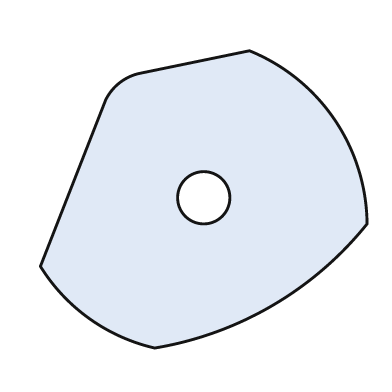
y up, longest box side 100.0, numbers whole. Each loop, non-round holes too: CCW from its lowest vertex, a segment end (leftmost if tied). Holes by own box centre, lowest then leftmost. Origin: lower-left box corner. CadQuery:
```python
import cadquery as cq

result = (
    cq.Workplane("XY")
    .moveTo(35.0, 0.0)
    .threePointArc((71.0, 13.0), (100.0, 38.0))
    .threePointArc((90.0, 70.0), (64.0, 91.0))
    .lineTo(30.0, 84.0)
    .threePointArc((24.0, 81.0), (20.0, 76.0))
    .lineTo(0.0, 25.0)
    .threePointArc((15.0, 9.0), (35.0, 0.0))
    .close()
    .moveTo(50.0, 46.0)
    .circle(8.0)
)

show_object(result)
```